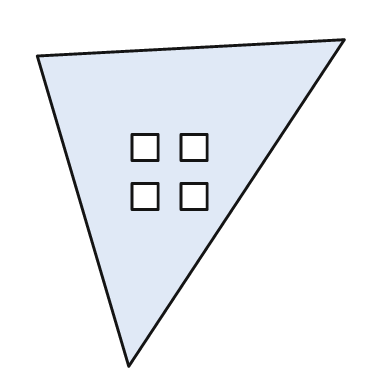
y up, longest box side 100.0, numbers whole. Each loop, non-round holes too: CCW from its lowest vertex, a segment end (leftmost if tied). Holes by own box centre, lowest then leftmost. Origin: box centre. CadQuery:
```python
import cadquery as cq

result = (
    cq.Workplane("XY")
    .moveTo(-19.0, -50.0)
    .lineTo(47.0, 50.0)
    .lineTo(-47.0, 45.0)
    .close()
    .moveTo(-18.0, -2.0)
    .lineTo(-10.0, -2.0)
    .lineTo(-10.0, 6.0)
    .lineTo(-18.0, 6.0)
    .close()
    .moveTo(-3.0, -2.0)
    .lineTo(5.0, -2.0)
    .lineTo(5.0, 6.0)
    .lineTo(-3.0, 6.0)
    .close()
    .moveTo(-18.0, 13.0)
    .lineTo(-10.0, 13.0)
    .lineTo(-10.0, 21.0)
    .lineTo(-18.0, 21.0)
    .close()
    .moveTo(-3.0, 13.0)
    .lineTo(5.0, 13.0)
    .lineTo(5.0, 21.0)
    .lineTo(-3.0, 21.0)
    .close()
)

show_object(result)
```